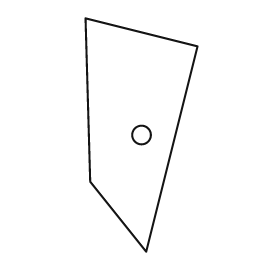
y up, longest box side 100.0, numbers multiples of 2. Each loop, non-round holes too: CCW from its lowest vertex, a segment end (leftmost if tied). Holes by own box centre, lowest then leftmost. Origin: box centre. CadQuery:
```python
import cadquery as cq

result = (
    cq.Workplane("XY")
    .moveTo(2.0, -50.0)
    .lineTo(24.0, 38.0)
    .lineTo(-24.0, 50.0)
    .lineTo(-22.0, -20.0)
    .close()
    .moveTo(0.0, 0.0)
    .circle(4.0)
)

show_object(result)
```